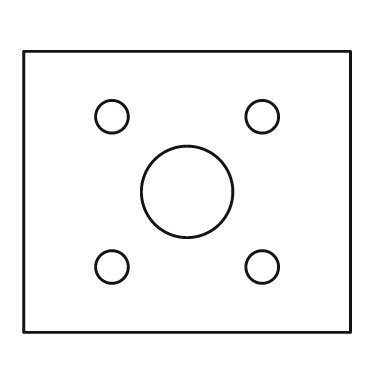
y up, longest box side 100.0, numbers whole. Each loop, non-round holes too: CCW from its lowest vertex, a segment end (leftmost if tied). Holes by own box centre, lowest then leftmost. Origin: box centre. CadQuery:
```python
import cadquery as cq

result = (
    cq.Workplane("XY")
    .moveTo(-50.0, -43.0)
    .lineTo(50.0, -43.0)
    .lineTo(50.0, 43.0)
    .lineTo(-50.0, 43.0)
    .close()
    .moveTo(-23.0, -23.0)
    .circle(5.0)
    .moveTo(23.0, -23.0)
    .circle(5.0)
    .moveTo(0.0, 0.0)
    .circle(14.0)
    .moveTo(-23.0, 23.0)
    .circle(5.0)
    .moveTo(23.0, 23.0)
    .circle(5.0)
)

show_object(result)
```